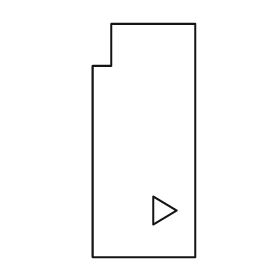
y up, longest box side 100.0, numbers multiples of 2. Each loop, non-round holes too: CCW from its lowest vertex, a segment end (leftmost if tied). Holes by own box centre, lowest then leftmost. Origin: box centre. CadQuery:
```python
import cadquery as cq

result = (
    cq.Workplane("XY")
    .moveTo(-22.0, -50.0)
    .lineTo(22.0, -50.0)
    .lineTo(22.0, 50.0)
    .lineTo(-14.0, 50.0)
    .lineTo(-14.0, 32.0)
    .lineTo(-22.0, 32.0)
    .close()
    .moveTo(4.0, -36.0)
    .lineTo(14.0, -30.0)
    .lineTo(4.0, -24.0)
    .close()
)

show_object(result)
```